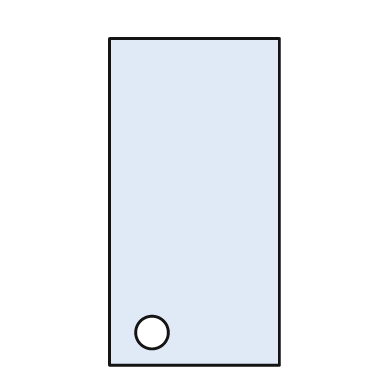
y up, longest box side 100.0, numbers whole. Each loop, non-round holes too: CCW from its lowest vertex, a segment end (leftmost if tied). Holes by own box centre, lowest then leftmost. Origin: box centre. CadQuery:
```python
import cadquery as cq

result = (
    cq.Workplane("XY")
    .moveTo(-26.0, -50.0)
    .lineTo(26.0, -50.0)
    .lineTo(26.0, 50.0)
    .lineTo(-26.0, 50.0)
    .close()
    .moveTo(-13.0, -40.0)
    .circle(5.0)
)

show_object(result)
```